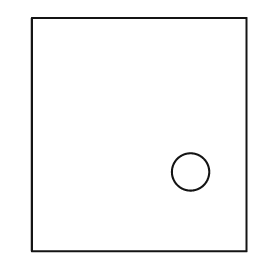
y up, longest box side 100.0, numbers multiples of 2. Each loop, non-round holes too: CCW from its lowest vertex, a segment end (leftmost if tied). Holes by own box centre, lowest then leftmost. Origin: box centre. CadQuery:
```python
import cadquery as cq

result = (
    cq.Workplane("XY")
    .moveTo(-46.0, -50.0)
    .lineTo(46.0, -50.0)
    .lineTo(46.0, 50.0)
    .lineTo(-46.0, 50.0)
    .close()
    .moveTo(22.0, -16.0)
    .circle(8.0)
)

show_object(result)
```